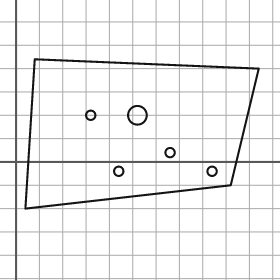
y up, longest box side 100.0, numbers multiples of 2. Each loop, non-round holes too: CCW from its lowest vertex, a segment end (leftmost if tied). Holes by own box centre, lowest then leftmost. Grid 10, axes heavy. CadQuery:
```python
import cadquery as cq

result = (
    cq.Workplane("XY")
    .moveTo(4.0, -20.0)
    .lineTo(92.0, -10.0)
    .lineTo(104.0, 40.0)
    .lineTo(8.0, 44.0)
    .close()
    .moveTo(44.0, -4.0)
    .circle(2.0)
    .moveTo(84.0, -4.0)
    .circle(2.0)
    .moveTo(66.0, 4.0)
    .circle(2.0)
    .moveTo(32.0, 20.0)
    .circle(2.0)
    .moveTo(52.0, 20.0)
    .circle(4.0)
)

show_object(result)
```